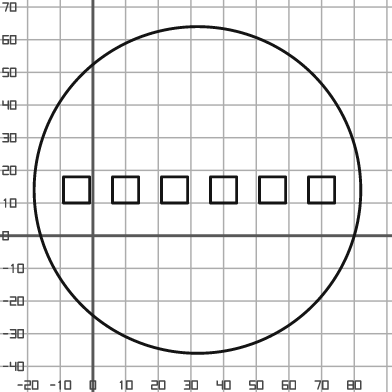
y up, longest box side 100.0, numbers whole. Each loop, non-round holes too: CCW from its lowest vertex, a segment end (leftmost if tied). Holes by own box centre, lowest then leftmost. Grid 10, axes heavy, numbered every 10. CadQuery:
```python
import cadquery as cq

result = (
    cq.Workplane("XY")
    .moveTo(32.0, 14.0)
    .circle(50.0)
    .moveTo(-9.0, 10.0)
    .lineTo(-1.0, 10.0)
    .lineTo(-1.0, 18.0)
    .lineTo(-9.0, 18.0)
    .close()
    .moveTo(6.0, 10.0)
    .lineTo(14.0, 10.0)
    .lineTo(14.0, 18.0)
    .lineTo(6.0, 18.0)
    .close()
    .moveTo(21.0, 10.0)
    .lineTo(29.0, 10.0)
    .lineTo(29.0, 18.0)
    .lineTo(21.0, 18.0)
    .close()
    .moveTo(36.0, 10.0)
    .lineTo(44.0, 10.0)
    .lineTo(44.0, 18.0)
    .lineTo(36.0, 18.0)
    .close()
    .moveTo(51.0, 10.0)
    .lineTo(59.0, 10.0)
    .lineTo(59.0, 18.0)
    .lineTo(51.0, 18.0)
    .close()
    .moveTo(66.0, 10.0)
    .lineTo(74.0, 10.0)
    .lineTo(74.0, 18.0)
    .lineTo(66.0, 18.0)
    .close()
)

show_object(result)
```